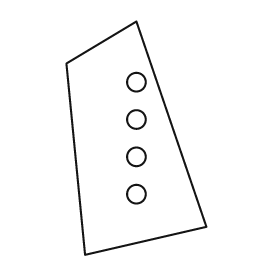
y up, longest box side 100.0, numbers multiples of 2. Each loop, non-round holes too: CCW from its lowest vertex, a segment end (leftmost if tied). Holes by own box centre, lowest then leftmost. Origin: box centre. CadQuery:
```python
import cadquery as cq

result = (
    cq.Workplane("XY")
    .moveTo(-22.0, -50.0)
    .lineTo(30.0, -38.0)
    .lineTo(0.0, 50.0)
    .lineTo(-30.0, 32.0)
    .close()
    .moveTo(0.0, -24.0)
    .circle(4.0)
    .moveTo(0.0, -8.0)
    .circle(4.0)
    .moveTo(0.0, 8.0)
    .circle(4.0)
    .moveTo(0.0, 24.0)
    .circle(4.0)
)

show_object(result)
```